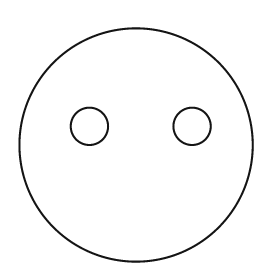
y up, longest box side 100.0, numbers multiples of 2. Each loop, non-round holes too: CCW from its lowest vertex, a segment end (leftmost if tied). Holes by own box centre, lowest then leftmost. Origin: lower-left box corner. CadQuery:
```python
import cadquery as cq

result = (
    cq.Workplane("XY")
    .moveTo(50.0, 50.0)
    .circle(50.0)
    .moveTo(30.0, 58.0)
    .circle(8.0)
    .moveTo(74.0, 58.0)
    .circle(8.0)
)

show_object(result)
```